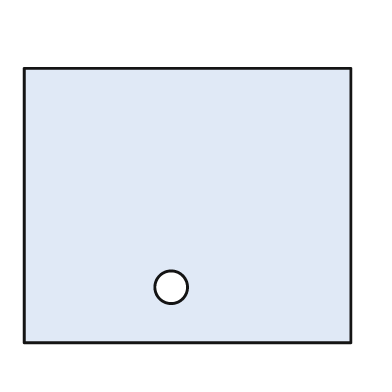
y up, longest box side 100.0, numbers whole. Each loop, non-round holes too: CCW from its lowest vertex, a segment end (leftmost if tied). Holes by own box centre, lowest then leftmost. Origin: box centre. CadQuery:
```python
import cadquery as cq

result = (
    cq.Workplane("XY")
    .moveTo(-50.0, -42.0)
    .lineTo(50.0, -42.0)
    .lineTo(50.0, 42.0)
    .lineTo(-50.0, 42.0)
    .close()
    .moveTo(-5.0, -25.0)
    .circle(5.0)
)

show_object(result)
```